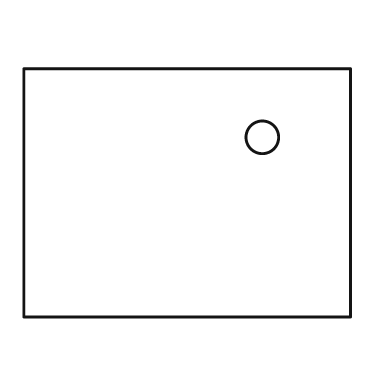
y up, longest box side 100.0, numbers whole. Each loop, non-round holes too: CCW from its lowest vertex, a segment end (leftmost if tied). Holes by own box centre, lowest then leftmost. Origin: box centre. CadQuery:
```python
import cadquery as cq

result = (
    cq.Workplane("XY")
    .moveTo(-50.0, -38.0)
    .lineTo(50.0, -38.0)
    .lineTo(50.0, 38.0)
    .lineTo(-50.0, 38.0)
    .close()
    .moveTo(23.0, 17.0)
    .circle(5.0)
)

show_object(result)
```